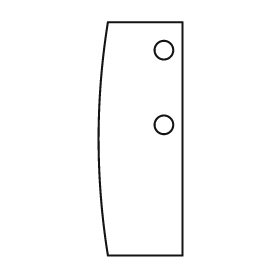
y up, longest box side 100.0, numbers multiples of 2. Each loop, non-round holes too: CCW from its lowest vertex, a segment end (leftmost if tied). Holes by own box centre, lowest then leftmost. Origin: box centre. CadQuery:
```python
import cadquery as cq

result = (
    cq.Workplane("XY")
    .moveTo(-14.0, -50.0)
    .lineTo(18.0, -50.0)
    .lineTo(18.0, 50.0)
    .lineTo(-14.0, 50.0)
    .threePointArc((-18.0, 0.0), (-14.0, -50.0))
    .close()
    .moveTo(10.0, 6.0)
    .circle(4.0)
    .moveTo(10.0, 38.0)
    .circle(4.0)
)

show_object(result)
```